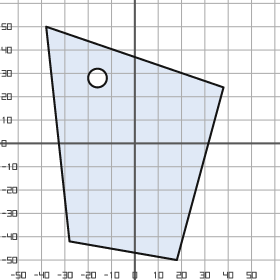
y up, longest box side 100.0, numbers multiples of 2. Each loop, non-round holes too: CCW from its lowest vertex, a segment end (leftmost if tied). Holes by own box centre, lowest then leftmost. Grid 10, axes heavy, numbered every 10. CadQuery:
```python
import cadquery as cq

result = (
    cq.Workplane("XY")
    .moveTo(18.0, -50.0)
    .lineTo(38.0, 24.0)
    .lineTo(-38.0, 50.0)
    .lineTo(-28.0, -42.0)
    .close()
    .moveTo(-16.0, 28.0)
    .circle(4.0)
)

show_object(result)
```